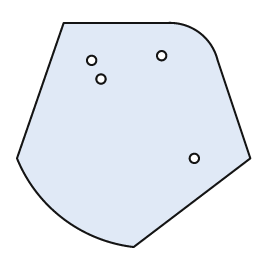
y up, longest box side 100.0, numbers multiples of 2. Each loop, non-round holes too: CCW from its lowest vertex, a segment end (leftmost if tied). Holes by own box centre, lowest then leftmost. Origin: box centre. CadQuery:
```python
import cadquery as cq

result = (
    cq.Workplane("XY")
    .moveTo(0.0, -48.0)
    .lineTo(50.0, -10.0)
    .lineTo(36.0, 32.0)
    .threePointArc((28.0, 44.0), (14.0, 48.0))
    .lineTo(-30.0, 48.0)
    .lineTo(-50.0, -10.0)
    .threePointArc((-30.0, -36.0), (0.0, -48.0))
    .close()
    .moveTo(26.0, -10.0)
    .circle(2.0)
    .moveTo(-14.0, 24.0)
    .circle(2.0)
    .moveTo(-18.0, 32.0)
    .circle(2.0)
    .moveTo(12.0, 34.0)
    .circle(2.0)
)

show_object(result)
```